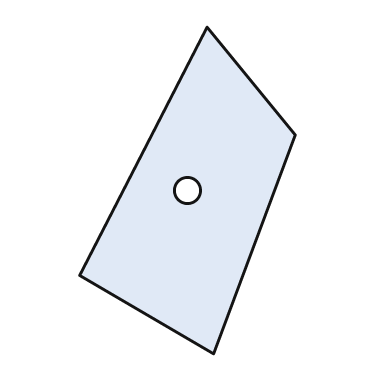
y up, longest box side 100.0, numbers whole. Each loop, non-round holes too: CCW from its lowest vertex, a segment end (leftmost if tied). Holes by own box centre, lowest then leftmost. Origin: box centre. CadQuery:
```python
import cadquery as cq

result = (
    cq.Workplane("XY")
    .moveTo(8.0, -50.0)
    .lineTo(33.0, 17.0)
    .lineTo(6.0, 50.0)
    .lineTo(-33.0, -26.0)
    .close()
    .moveTo(0.0, 0.0)
    .circle(4.0)
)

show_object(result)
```